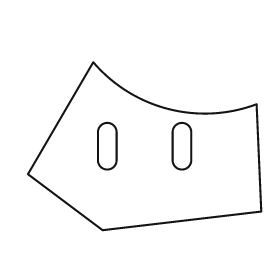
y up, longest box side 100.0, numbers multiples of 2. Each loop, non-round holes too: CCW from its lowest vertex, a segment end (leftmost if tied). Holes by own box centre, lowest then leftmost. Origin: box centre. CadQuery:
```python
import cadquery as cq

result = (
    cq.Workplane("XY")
    .moveTo(-18.0, -36.0)
    .lineTo(50.0, -28.0)
    .lineTo(48.0, 18.0)
    .threePointArc((10.0, 16.0), (-22.0, 36.0))
    .lineTo(-50.0, -12.0)
    .close()
    .moveTo(-20.0, -6.0)
    .threePointArc((-16.0, -10.0), (-12.0, -6.0))
    .lineTo(-12.0, 6.0)
    .threePointArc((-16.0, 10.0), (-20.0, 6.0))
    .close()
    .moveTo(12.0, -6.0)
    .threePointArc((16.0, -10.0), (20.0, -6.0))
    .lineTo(20.0, 6.0)
    .threePointArc((16.0, 10.0), (12.0, 6.0))
    .close()
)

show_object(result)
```